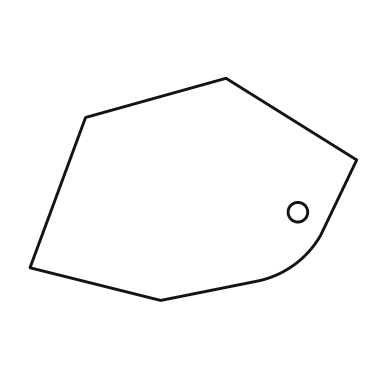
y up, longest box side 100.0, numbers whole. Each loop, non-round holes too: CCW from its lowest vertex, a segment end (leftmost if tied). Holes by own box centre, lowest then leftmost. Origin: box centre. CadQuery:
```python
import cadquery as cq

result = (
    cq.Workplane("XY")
    .moveTo(-10.0, -34.0)
    .lineTo(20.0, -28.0)
    .threePointArc((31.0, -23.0), (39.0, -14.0))
    .lineTo(50.0, 9.0)
    .lineTo(10.0, 34.0)
    .lineTo(-33.0, 22.0)
    .lineTo(-50.0, -24.0)
    .close()
    .moveTo(32.0, -7.0)
    .circle(3.0)
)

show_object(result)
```